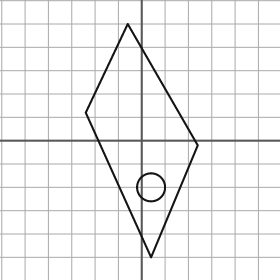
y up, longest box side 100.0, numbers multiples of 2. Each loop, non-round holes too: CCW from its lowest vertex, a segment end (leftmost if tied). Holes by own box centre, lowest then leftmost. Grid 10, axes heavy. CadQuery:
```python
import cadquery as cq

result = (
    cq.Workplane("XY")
    .moveTo(4.0, -50.0)
    .lineTo(24.0, -2.0)
    .lineTo(-6.0, 50.0)
    .lineTo(-24.0, 12.0)
    .close()
    .moveTo(4.0, -20.0)
    .circle(6.0)
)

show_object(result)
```